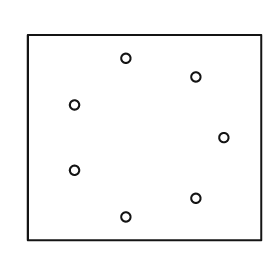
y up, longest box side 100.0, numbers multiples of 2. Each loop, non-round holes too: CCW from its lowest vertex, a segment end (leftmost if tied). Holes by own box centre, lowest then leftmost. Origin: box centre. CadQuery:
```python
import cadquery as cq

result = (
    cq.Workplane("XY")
    .moveTo(-50.0, -44.0)
    .lineTo(50.0, -44.0)
    .lineTo(50.0, 44.0)
    .lineTo(-50.0, 44.0)
    .close()
    .moveTo(-8.0, -34.0)
    .circle(2.0)
    .moveTo(22.0, -26.0)
    .circle(2.0)
    .moveTo(-30.0, -14.0)
    .circle(2.0)
    .moveTo(34.0, 0.0)
    .circle(2.0)
    .moveTo(-30.0, 14.0)
    .circle(2.0)
    .moveTo(22.0, 26.0)
    .circle(2.0)
    .moveTo(-8.0, 34.0)
    .circle(2.0)
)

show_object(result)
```